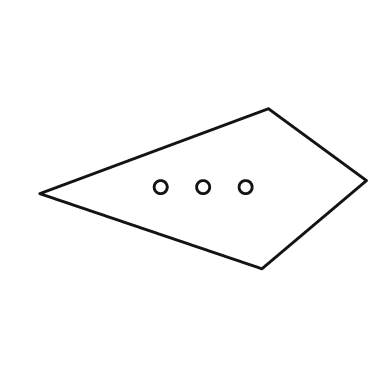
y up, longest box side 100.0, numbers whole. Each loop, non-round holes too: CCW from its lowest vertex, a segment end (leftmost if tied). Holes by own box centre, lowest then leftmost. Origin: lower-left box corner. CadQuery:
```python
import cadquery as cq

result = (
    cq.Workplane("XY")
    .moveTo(68.0, 0.0)
    .lineTo(100.0, 27.0)
    .lineTo(70.0, 49.0)
    .lineTo(0.0, 23.0)
    .close()
    .moveTo(37.0, 25.0)
    .circle(2.0)
    .moveTo(50.0, 25.0)
    .circle(2.0)
    .moveTo(63.0, 25.0)
    .circle(2.0)
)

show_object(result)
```